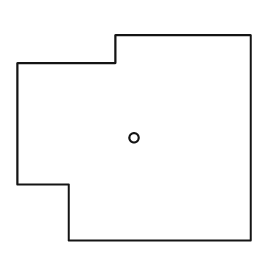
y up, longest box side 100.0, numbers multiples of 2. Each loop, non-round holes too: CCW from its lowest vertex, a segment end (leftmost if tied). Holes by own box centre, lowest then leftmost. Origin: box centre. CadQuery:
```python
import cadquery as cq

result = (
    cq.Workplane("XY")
    .moveTo(-28.0, -44.0)
    .lineTo(50.0, -44.0)
    .lineTo(50.0, 44.0)
    .lineTo(-8.0, 44.0)
    .lineTo(-8.0, 32.0)
    .lineTo(-50.0, 32.0)
    .lineTo(-50.0, -20.0)
    .lineTo(-28.0, -20.0)
    .close()
    .moveTo(0.0, 0.0)
    .circle(2.0)
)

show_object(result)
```